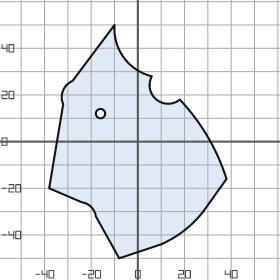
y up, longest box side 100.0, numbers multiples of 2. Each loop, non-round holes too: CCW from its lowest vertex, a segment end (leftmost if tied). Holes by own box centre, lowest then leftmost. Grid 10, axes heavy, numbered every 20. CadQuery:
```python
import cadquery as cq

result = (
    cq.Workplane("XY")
    .moveTo(-8.0, -50.0)
    .lineTo(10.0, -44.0)
    .threePointArc((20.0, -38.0), (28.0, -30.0))
    .lineTo(38.0, -16.0)
    .threePointArc((30.0, 2.0), (18.0, 18.0))
    .threePointArc((8.0, 18.0), (6.0, 28.0))
    .threePointArc((-6.0, 36.0), (-10.0, 50.0))
    .lineTo(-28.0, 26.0)
    .threePointArc((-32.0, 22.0), (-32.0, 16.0))
    .lineTo(-38.0, -20.0)
    .lineTo(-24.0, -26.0)
    .threePointArc((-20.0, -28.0), (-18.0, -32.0))
    .close()
    .moveTo(-16.0, 12.0)
    .circle(2.0)
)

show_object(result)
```